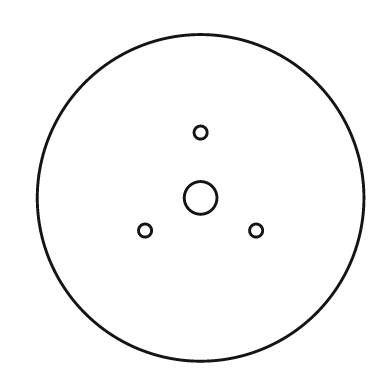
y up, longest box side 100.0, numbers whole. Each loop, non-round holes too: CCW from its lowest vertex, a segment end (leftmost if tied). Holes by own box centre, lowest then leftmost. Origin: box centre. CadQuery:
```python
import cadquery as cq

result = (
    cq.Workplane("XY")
    .moveTo(0.0, 0.0)
    .circle(50.0)
    .moveTo(-17.0, -10.0)
    .circle(2.0)
    .moveTo(17.0, -10.0)
    .circle(2.0)
    .moveTo(0.0, 0.0)
    .circle(5.0)
    .moveTo(0.0, 20.0)
    .circle(2.0)
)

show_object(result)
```